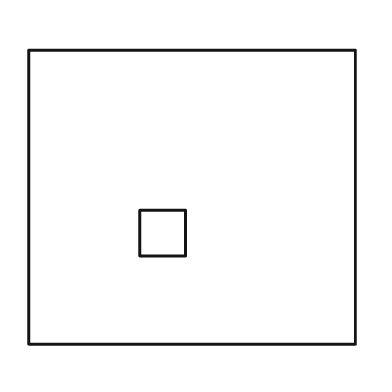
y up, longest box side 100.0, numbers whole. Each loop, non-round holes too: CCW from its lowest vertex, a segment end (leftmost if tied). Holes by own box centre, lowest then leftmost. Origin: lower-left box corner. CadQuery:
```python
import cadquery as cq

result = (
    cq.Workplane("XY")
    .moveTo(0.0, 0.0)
    .lineTo(100.0, 0.0)
    .lineTo(100.0, 90.0)
    .lineTo(0.0, 90.0)
    .close()
    .moveTo(34.0, 27.0)
    .lineTo(48.0, 27.0)
    .lineTo(48.0, 41.0)
    .lineTo(34.0, 41.0)
    .close()
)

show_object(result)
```